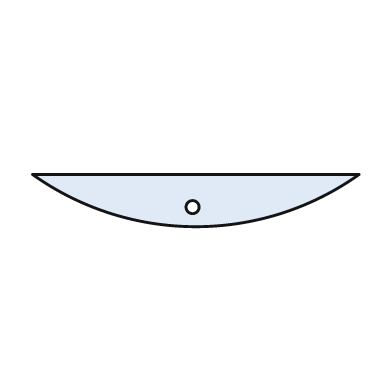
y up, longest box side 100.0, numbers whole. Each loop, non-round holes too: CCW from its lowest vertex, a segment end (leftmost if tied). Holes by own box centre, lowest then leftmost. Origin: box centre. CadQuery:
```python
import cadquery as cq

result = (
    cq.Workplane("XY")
    .moveTo(-50.0, 8.0)
    .threePointArc((0.0, -8.0), (50.0, 8.0))
    .close()
    .moveTo(-1.0, -2.0)
    .circle(2.0)
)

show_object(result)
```